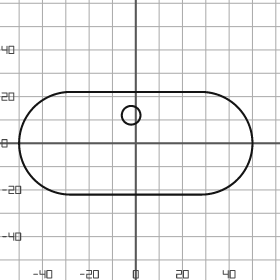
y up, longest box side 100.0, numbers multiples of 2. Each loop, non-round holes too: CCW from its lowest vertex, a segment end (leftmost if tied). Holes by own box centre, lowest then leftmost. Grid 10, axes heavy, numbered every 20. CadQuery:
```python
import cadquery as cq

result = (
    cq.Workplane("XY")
    .moveTo(-28.0, -22.0)
    .lineTo(28.0, -22.0)
    .threePointArc((50.0, 0.0), (28.0, 22.0))
    .lineTo(-28.0, 22.0)
    .threePointArc((-50.0, 0.0), (-28.0, -22.0))
    .close()
    .moveTo(-2.0, 12.0)
    .circle(4.0)
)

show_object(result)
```